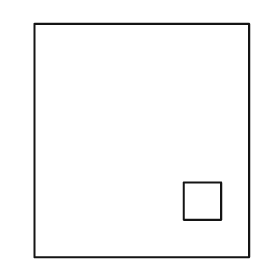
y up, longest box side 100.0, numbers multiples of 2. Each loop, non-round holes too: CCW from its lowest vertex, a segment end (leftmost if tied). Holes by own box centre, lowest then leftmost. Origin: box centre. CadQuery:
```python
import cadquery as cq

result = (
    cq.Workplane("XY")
    .moveTo(-46.0, -50.0)
    .lineTo(46.0, -50.0)
    .lineTo(46.0, 50.0)
    .lineTo(-46.0, 50.0)
    .close()
    .moveTo(18.0, -34.0)
    .lineTo(34.0, -34.0)
    .lineTo(34.0, -18.0)
    .lineTo(18.0, -18.0)
    .close()
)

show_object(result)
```